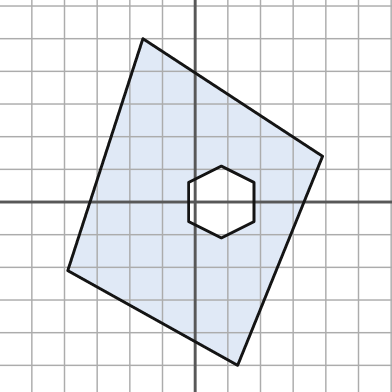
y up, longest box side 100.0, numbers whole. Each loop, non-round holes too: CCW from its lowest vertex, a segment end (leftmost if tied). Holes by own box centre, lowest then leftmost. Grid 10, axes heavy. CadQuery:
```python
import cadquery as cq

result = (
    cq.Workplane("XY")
    .moveTo(13.0, -50.0)
    .lineTo(39.0, 14.0)
    .lineTo(-16.0, 50.0)
    .lineTo(-39.0, -21.0)
    .close()
    .moveTo(8.0, -11.0)
    .lineTo(18.0, -6.0)
    .lineTo(18.0, 6.0)
    .lineTo(8.0, 11.0)
    .lineTo(-2.0, 6.0)
    .lineTo(-2.0, -6.0)
    .close()
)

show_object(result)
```